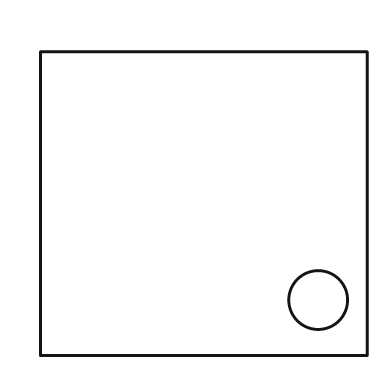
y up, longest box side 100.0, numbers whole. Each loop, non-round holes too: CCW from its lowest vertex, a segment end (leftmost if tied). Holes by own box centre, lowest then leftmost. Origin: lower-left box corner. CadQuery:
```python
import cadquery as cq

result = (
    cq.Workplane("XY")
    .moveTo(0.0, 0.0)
    .lineTo(100.0, 0.0)
    .lineTo(100.0, 93.0)
    .lineTo(0.0, 93.0)
    .close()
    .moveTo(85.0, 17.0)
    .circle(9.0)
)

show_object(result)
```